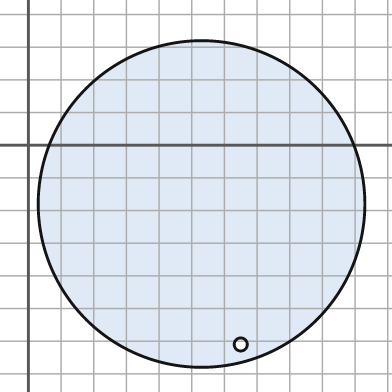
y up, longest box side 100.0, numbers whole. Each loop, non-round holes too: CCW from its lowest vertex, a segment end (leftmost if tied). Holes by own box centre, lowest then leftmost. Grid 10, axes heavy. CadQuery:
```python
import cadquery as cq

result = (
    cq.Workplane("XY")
    .moveTo(53.0, -18.0)
    .circle(50.0)
    .moveTo(65.0, -61.0)
    .circle(2.0)
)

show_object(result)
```